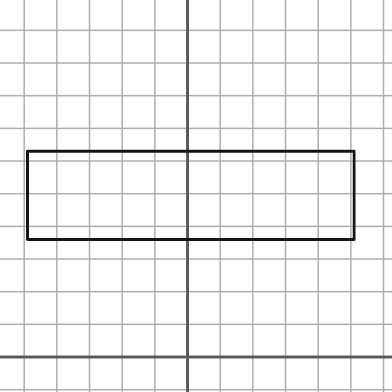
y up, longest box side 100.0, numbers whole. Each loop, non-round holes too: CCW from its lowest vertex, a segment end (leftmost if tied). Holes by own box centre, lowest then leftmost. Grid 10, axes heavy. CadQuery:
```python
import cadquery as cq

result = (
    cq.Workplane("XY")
    .moveTo(-49.0, 36.0)
    .lineTo(51.0, 36.0)
    .lineTo(51.0, 63.0)
    .lineTo(-49.0, 63.0)
    .close()
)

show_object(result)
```